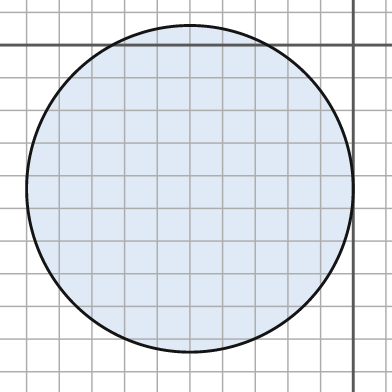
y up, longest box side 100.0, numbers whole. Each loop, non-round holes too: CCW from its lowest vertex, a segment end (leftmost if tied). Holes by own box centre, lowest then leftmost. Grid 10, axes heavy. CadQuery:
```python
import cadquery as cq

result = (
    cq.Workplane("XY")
    .moveTo(-50.0, -44.0)
    .circle(50.0)
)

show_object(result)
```